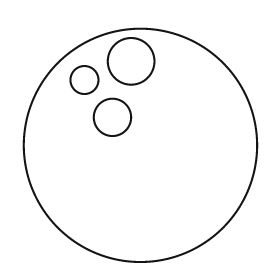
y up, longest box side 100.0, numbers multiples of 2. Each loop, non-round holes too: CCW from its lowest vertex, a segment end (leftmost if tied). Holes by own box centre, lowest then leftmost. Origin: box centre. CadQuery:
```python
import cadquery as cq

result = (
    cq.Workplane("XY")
    .moveTo(0.0, 0.0)
    .circle(50.0)
    .moveTo(-12.0, 12.0)
    .circle(8.0)
    .moveTo(-24.0, 28.0)
    .circle(6.0)
    .moveTo(-4.0, 36.0)
    .circle(10.0)
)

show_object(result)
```